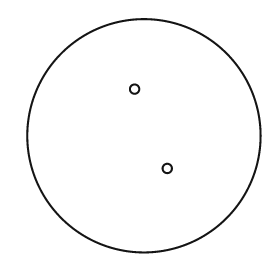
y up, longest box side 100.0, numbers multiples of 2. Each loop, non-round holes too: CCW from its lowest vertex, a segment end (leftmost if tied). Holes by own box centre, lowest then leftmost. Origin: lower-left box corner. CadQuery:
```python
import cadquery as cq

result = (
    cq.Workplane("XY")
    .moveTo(50.0, 50.0)
    .circle(50.0)
    .moveTo(60.0, 36.0)
    .circle(2.0)
    .moveTo(46.0, 70.0)
    .circle(2.0)
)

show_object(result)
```